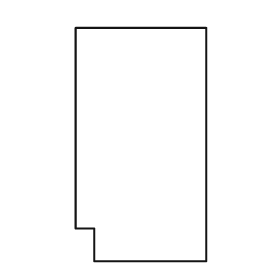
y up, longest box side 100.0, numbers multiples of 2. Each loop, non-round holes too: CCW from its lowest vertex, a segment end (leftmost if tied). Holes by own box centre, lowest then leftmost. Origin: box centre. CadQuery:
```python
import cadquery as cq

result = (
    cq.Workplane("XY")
    .moveTo(-20.0, -50.0)
    .lineTo(28.0, -50.0)
    .lineTo(28.0, 50.0)
    .lineTo(-28.0, 50.0)
    .lineTo(-28.0, -36.0)
    .lineTo(-20.0, -36.0)
    .close()
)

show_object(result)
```